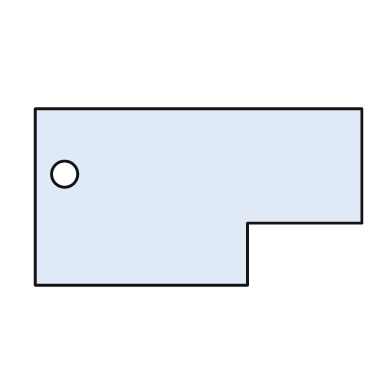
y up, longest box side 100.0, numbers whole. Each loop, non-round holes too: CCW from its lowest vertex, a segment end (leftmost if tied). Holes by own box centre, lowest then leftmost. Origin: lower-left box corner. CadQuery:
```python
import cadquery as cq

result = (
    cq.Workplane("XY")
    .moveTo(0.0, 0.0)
    .lineTo(65.0, 0.0)
    .lineTo(65.0, 19.0)
    .lineTo(100.0, 19.0)
    .lineTo(100.0, 54.0)
    .lineTo(0.0, 54.0)
    .close()
    .moveTo(9.0, 34.0)
    .circle(4.0)
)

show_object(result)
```